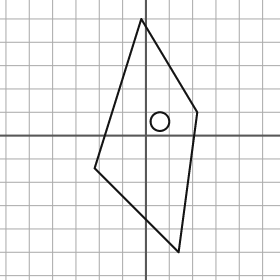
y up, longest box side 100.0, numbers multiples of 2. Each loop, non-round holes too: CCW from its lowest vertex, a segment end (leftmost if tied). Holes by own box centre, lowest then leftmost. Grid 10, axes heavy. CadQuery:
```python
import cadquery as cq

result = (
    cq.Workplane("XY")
    .moveTo(14.0, -50.0)
    .lineTo(22.0, 10.0)
    .lineTo(-2.0, 50.0)
    .lineTo(-22.0, -14.0)
    .close()
    .moveTo(6.0, 6.0)
    .circle(4.0)
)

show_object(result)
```